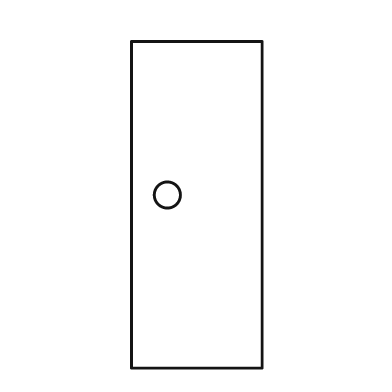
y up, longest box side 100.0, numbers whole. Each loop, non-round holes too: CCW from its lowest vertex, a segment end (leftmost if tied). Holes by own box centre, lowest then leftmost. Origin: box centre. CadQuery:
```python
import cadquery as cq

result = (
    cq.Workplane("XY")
    .moveTo(-20.0, -50.0)
    .lineTo(20.0, -50.0)
    .lineTo(20.0, 50.0)
    .lineTo(-20.0, 50.0)
    .close()
    .moveTo(-9.0, 3.0)
    .circle(4.0)
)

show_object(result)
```